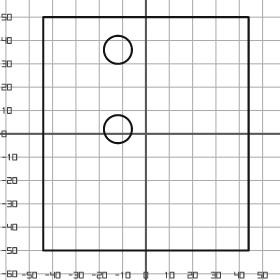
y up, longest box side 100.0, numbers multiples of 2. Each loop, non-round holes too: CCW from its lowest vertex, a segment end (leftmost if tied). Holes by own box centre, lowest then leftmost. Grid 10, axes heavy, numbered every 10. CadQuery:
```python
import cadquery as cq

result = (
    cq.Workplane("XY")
    .moveTo(-44.0, -50.0)
    .lineTo(44.0, -50.0)
    .lineTo(44.0, 50.0)
    .lineTo(-44.0, 50.0)
    .close()
    .moveTo(-12.0, 2.0)
    .circle(6.0)
    .moveTo(-12.0, 36.0)
    .circle(6.0)
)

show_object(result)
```